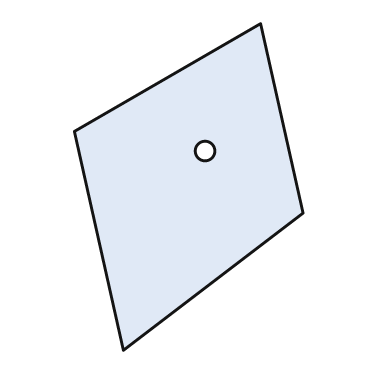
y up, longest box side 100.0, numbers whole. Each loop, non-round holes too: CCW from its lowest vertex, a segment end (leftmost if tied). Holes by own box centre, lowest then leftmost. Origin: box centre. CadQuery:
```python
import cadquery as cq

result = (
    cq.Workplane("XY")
    .moveTo(-20.0, -50.0)
    .lineTo(35.0, -8.0)
    .lineTo(22.0, 50.0)
    .lineTo(-35.0, 17.0)
    .close()
    .moveTo(5.0, 11.0)
    .circle(3.0)
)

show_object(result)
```